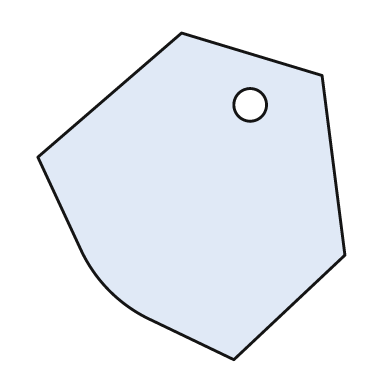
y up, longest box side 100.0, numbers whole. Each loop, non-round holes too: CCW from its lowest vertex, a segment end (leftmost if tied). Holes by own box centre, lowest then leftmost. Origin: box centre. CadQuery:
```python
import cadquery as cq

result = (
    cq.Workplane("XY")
    .moveTo(13.0, -50.0)
    .lineTo(47.0, -18.0)
    .lineTo(40.0, 37.0)
    .lineTo(-3.0, 50.0)
    .lineTo(-47.0, 12.0)
    .lineTo(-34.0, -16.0)
    .threePointArc((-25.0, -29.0), (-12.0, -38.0))
    .close()
    .moveTo(18.0, 28.0)
    .circle(5.0)
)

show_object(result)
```